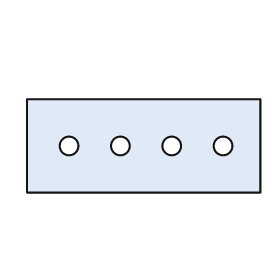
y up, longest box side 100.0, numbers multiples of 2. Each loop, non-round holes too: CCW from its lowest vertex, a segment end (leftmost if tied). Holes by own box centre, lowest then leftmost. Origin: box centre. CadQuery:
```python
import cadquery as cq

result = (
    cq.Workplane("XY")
    .moveTo(-50.0, -20.0)
    .lineTo(50.0, -20.0)
    .lineTo(50.0, 20.0)
    .lineTo(-50.0, 20.0)
    .close()
    .moveTo(-32.0, 0.0)
    .circle(4.0)
    .moveTo(-10.0, 0.0)
    .circle(4.0)
    .moveTo(12.0, 0.0)
    .circle(4.0)
    .moveTo(34.0, 0.0)
    .circle(4.0)
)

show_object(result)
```